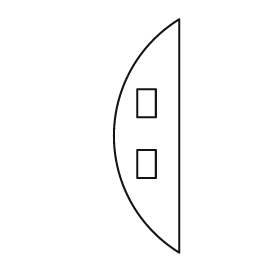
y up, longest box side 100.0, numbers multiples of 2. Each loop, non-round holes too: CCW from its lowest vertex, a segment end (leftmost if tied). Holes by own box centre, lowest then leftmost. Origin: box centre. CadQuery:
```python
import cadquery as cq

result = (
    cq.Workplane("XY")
    .moveTo(14.0, -50.0)
    .lineTo(14.0, 50.0)
    .threePointArc((-14.0, 0.0), (14.0, -50.0))
    .close()
    .moveTo(-4.0, -18.0)
    .lineTo(4.0, -18.0)
    .lineTo(4.0, -6.0)
    .lineTo(-4.0, -6.0)
    .close()
    .moveTo(-4.0, 8.0)
    .lineTo(4.0, 8.0)
    .lineTo(4.0, 20.0)
    .lineTo(-4.0, 20.0)
    .close()
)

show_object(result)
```